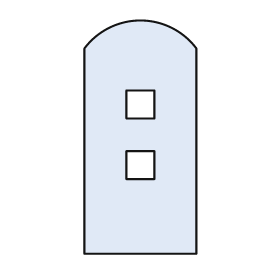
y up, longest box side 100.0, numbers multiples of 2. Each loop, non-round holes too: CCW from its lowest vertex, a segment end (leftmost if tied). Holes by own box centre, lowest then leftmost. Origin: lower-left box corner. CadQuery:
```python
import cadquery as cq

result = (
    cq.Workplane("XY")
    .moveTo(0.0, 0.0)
    .lineTo(48.0, 0.0)
    .lineTo(48.0, 88.0)
    .threePointArc((24.0, 100.0), (0.0, 88.0))
    .close()
    .moveTo(18.0, 32.0)
    .lineTo(30.0, 32.0)
    .lineTo(30.0, 44.0)
    .lineTo(18.0, 44.0)
    .close()
    .moveTo(18.0, 58.0)
    .lineTo(30.0, 58.0)
    .lineTo(30.0, 70.0)
    .lineTo(18.0, 70.0)
    .close()
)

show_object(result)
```